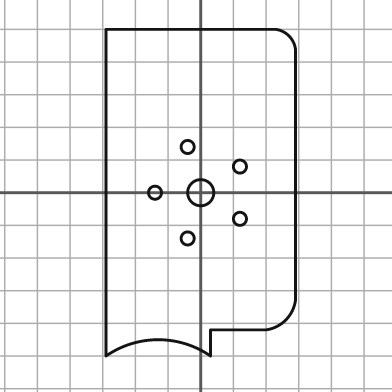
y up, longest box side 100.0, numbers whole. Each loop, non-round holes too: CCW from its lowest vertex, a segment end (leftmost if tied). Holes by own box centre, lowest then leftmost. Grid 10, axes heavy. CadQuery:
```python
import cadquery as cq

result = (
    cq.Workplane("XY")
    .moveTo(-29.0, -50.0)
    .threePointArc((-13.0, -45.0), (3.0, -50.0))
    .lineTo(3.0, -42.0)
    .lineTo(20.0, -42.0)
    .threePointArc((26.0, -39.0), (29.0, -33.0))
    .lineTo(29.0, 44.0)
    .threePointArc((27.0, 48.0), (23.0, 50.0))
    .lineTo(-29.0, 50.0)
    .close()
    .moveTo(-4.0, -14.0)
    .circle(2.0)
    .moveTo(12.0, -8.0)
    .circle(2.0)
    .moveTo(-14.0, 0.0)
    .circle(2.0)
    .moveTo(0.0, 0.0)
    .circle(4.0)
    .moveTo(12.0, 8.0)
    .circle(2.0)
    .moveTo(-4.0, 14.0)
    .circle(2.0)
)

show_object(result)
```